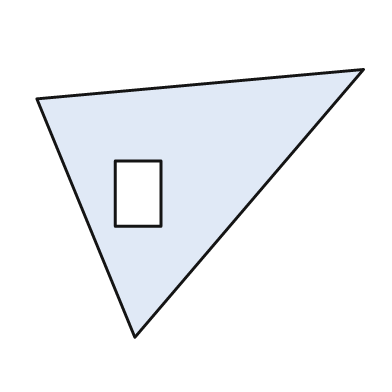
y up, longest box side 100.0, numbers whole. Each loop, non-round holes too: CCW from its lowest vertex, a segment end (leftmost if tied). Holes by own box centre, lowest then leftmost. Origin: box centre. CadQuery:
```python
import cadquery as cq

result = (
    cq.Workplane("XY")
    .moveTo(-20.0, -41.0)
    .lineTo(50.0, 41.0)
    .lineTo(-50.0, 32.0)
    .close()
    .moveTo(-26.0, -7.0)
    .lineTo(-12.0, -7.0)
    .lineTo(-12.0, 13.0)
    .lineTo(-26.0, 13.0)
    .close()
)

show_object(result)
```